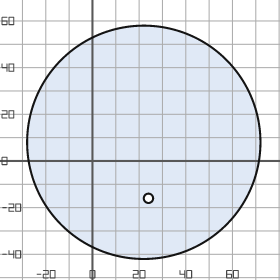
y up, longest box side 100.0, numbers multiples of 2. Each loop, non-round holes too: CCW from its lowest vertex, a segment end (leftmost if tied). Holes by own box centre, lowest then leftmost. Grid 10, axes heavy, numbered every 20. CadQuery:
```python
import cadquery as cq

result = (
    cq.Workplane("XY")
    .moveTo(22.0, 8.0)
    .circle(50.0)
    .moveTo(24.0, -16.0)
    .circle(2.0)
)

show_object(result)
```